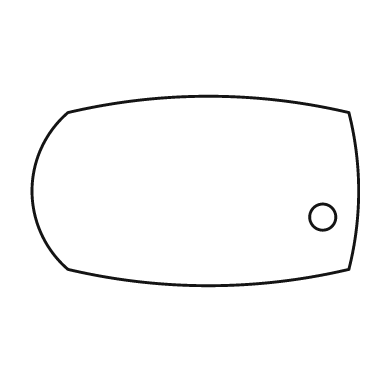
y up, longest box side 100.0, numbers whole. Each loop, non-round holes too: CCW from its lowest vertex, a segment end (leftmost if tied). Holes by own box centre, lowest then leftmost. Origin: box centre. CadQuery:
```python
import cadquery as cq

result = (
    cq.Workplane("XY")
    .moveTo(-39.0, -24.0)
    .threePointArc((4.0, -29.0), (47.0, -24.0))
    .threePointArc((50.0, 0.0), (47.0, 24.0))
    .threePointArc((4.0, 29.0), (-39.0, 24.0))
    .threePointArc((-50.0, 0.0), (-39.0, -24.0))
    .close()
    .moveTo(39.0, -8.0)
    .circle(4.0)
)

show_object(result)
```